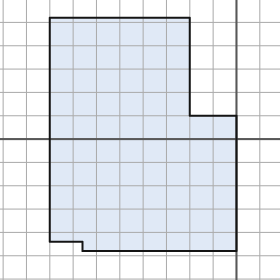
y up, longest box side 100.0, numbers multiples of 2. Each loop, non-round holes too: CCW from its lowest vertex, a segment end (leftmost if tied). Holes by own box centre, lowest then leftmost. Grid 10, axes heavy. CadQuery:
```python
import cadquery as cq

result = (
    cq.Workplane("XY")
    .moveTo(-66.0, -48.0)
    .lineTo(0.0, -48.0)
    .lineTo(0.0, 10.0)
    .lineTo(-20.0, 10.0)
    .lineTo(-20.0, 52.0)
    .lineTo(-80.0, 52.0)
    .lineTo(-80.0, -44.0)
    .lineTo(-66.0, -44.0)
    .close()
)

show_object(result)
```